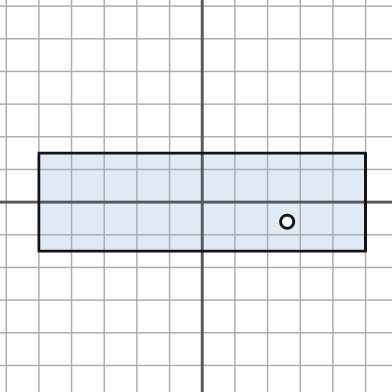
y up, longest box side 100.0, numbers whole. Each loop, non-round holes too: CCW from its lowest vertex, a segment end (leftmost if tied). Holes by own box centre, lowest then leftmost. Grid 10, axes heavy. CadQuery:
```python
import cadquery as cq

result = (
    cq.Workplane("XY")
    .moveTo(-50.0, -15.0)
    .lineTo(50.0, -15.0)
    .lineTo(50.0, 15.0)
    .lineTo(-50.0, 15.0)
    .close()
    .moveTo(26.0, -6.0)
    .circle(2.0)
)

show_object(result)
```